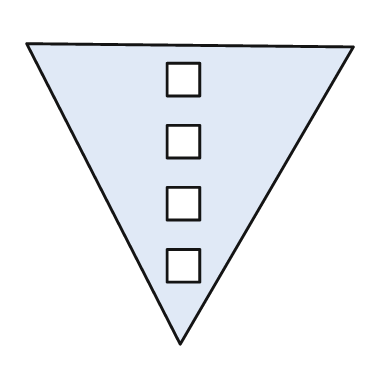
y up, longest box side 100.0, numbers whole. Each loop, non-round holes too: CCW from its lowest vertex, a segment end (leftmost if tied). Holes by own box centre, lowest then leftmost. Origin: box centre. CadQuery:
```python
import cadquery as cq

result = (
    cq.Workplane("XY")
    .moveTo(-3.0, -46.0)
    .lineTo(50.0, 45.0)
    .lineTo(-50.0, 46.0)
    .close()
    .moveTo(-7.0, -27.0)
    .lineTo(3.0, -27.0)
    .lineTo(3.0, -17.0)
    .lineTo(-7.0, -17.0)
    .close()
    .moveTo(-7.0, -8.0)
    .lineTo(3.0, -8.0)
    .lineTo(3.0, 2.0)
    .lineTo(-7.0, 2.0)
    .close()
    .moveTo(-7.0, 11.0)
    .lineTo(3.0, 11.0)
    .lineTo(3.0, 21.0)
    .lineTo(-7.0, 21.0)
    .close()
    .moveTo(-7.0, 30.0)
    .lineTo(3.0, 30.0)
    .lineTo(3.0, 40.0)
    .lineTo(-7.0, 40.0)
    .close()
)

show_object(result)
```